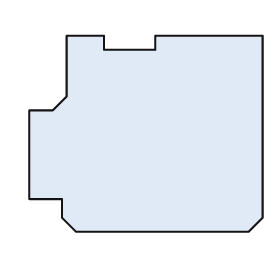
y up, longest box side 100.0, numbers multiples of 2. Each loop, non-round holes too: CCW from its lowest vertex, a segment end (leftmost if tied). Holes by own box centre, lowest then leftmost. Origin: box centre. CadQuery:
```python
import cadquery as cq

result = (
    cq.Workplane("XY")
    .moveTo(-30.0, -42.0)
    .lineTo(44.0, -42.0)
    .lineTo(50.0, -36.0)
    .lineTo(50.0, 42.0)
    .lineTo(4.0, 42.0)
    .lineTo(4.0, 36.0)
    .lineTo(-18.0, 36.0)
    .lineTo(-18.0, 42.0)
    .lineTo(-34.0, 42.0)
    .lineTo(-34.0, 16.0)
    .lineTo(-40.0, 10.0)
    .lineTo(-50.0, 10.0)
    .lineTo(-50.0, -28.0)
    .lineTo(-36.0, -28.0)
    .lineTo(-36.0, -36.0)
    .close()
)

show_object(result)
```